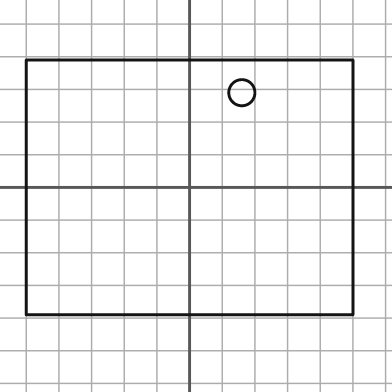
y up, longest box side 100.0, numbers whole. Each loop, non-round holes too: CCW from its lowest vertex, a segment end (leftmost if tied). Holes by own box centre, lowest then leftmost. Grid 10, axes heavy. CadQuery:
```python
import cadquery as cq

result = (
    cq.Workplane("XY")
    .moveTo(-50.0, -39.0)
    .lineTo(50.0, -39.0)
    .lineTo(50.0, 39.0)
    .lineTo(-50.0, 39.0)
    .close()
    .moveTo(16.0, 29.0)
    .circle(4.0)
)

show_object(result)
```